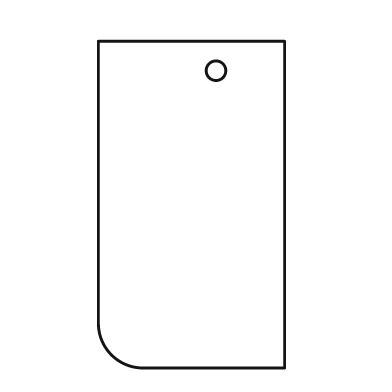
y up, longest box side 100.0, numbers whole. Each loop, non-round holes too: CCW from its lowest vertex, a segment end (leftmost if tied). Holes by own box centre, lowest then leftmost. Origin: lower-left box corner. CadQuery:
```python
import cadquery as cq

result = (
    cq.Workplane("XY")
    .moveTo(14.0, 0.0)
    .lineTo(57.0, 0.0)
    .lineTo(57.0, 100.0)
    .lineTo(0.0, 100.0)
    .lineTo(0.0, 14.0)
    .threePointArc((4.0, 4.0), (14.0, 0.0))
    .close()
    .moveTo(36.0, 91.0)
    .circle(3.0)
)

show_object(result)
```